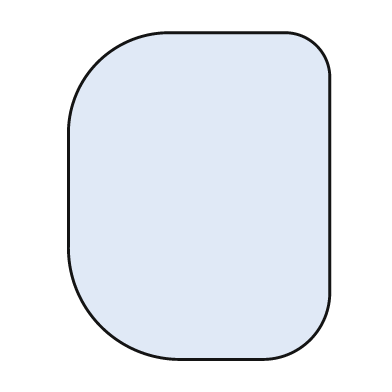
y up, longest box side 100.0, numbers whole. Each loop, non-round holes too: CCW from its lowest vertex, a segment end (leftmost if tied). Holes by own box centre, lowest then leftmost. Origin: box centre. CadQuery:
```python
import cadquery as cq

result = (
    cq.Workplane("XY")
    .moveTo(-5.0, -50.0)
    .lineTo(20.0, -50.0)
    .threePointArc((34.0, -44.0), (40.0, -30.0))
    .lineTo(40.0, 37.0)
    .threePointArc((36.0, 46.0), (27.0, 50.0))
    .lineTo(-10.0, 50.0)
    .threePointArc((-31.0, 41.0), (-40.0, 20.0))
    .lineTo(-40.0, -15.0)
    .threePointArc((-30.0, -40.0), (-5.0, -50.0))
    .close()
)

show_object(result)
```